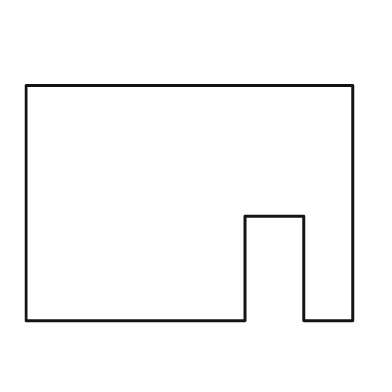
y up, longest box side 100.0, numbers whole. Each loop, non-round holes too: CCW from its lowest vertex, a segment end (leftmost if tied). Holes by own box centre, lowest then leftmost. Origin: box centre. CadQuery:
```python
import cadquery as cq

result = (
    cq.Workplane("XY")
    .moveTo(-50.0, -36.0)
    .lineTo(17.0, -36.0)
    .lineTo(17.0, -4.0)
    .lineTo(35.0, -4.0)
    .lineTo(35.0, -36.0)
    .lineTo(50.0, -36.0)
    .lineTo(50.0, 36.0)
    .lineTo(-50.0, 36.0)
    .close()
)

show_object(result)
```